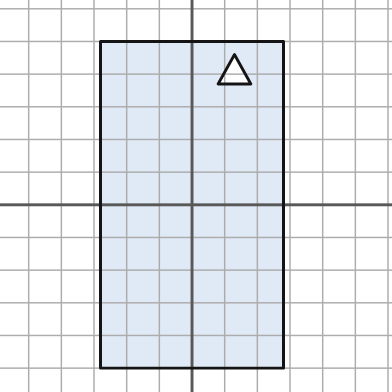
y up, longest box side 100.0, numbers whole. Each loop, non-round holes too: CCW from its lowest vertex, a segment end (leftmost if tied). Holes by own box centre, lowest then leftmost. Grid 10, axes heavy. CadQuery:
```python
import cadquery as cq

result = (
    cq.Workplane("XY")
    .moveTo(-28.0, -50.0)
    .lineTo(28.0, -50.0)
    .lineTo(28.0, 50.0)
    .lineTo(-28.0, 50.0)
    .close()
    .moveTo(8.0, 37.0)
    .lineTo(18.0, 37.0)
    .lineTo(13.0, 46.0)
    .close()
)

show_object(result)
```